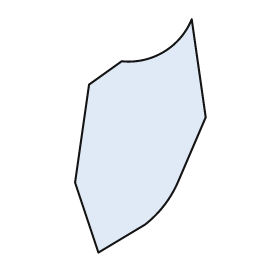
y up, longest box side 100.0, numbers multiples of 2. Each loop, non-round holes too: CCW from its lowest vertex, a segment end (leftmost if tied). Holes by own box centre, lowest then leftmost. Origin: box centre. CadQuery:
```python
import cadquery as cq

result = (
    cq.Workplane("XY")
    .moveTo(-18.0, -50.0)
    .lineTo(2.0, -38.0)
    .threePointArc((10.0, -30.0), (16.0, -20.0))
    .lineTo(28.0, 8.0)
    .lineTo(22.0, 50.0)
    .threePointArc((10.0, 36.0), (-8.0, 32.0))
    .lineTo(-22.0, 22.0)
    .lineTo(-28.0, -20.0)
    .close()
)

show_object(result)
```